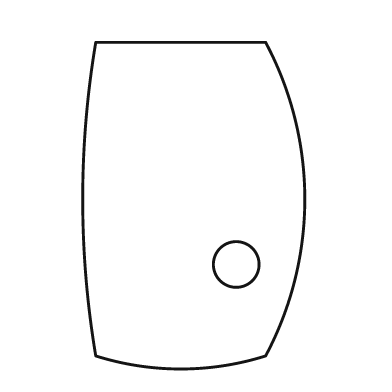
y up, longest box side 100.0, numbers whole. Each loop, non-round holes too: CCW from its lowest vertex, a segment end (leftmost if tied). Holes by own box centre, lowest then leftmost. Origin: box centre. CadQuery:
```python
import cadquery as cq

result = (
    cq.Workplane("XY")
    .moveTo(-30.0, -46.0)
    .threePointArc((-4.0, -50.0), (22.0, -46.0))
    .threePointArc((34.0, 2.0), (22.0, 50.0))
    .lineTo(-30.0, 50.0)
    .threePointArc((-34.0, 2.0), (-30.0, -46.0))
    .close()
    .moveTo(13.0, -18.0)
    .circle(7.0)
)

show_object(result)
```